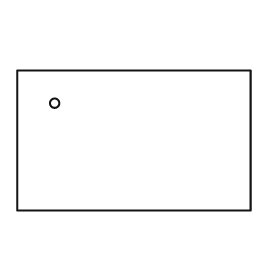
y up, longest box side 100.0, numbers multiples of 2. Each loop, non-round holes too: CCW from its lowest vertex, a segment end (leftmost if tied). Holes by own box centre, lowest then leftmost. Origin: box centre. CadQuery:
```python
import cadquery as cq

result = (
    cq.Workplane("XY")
    .moveTo(-50.0, -30.0)
    .lineTo(50.0, -30.0)
    .lineTo(50.0, 30.0)
    .lineTo(-50.0, 30.0)
    .close()
    .moveTo(-34.0, 16.0)
    .circle(2.0)
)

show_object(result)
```